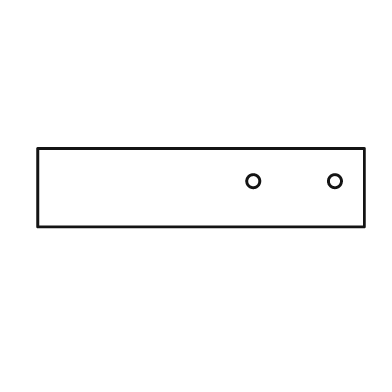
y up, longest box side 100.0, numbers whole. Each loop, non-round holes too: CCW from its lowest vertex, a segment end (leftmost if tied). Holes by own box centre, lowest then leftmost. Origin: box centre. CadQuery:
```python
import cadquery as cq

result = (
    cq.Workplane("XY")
    .moveTo(-50.0, -12.0)
    .lineTo(50.0, -12.0)
    .lineTo(50.0, 12.0)
    .lineTo(-50.0, 12.0)
    .close()
    .moveTo(16.0, 2.0)
    .circle(2.0)
    .moveTo(41.0, 2.0)
    .circle(2.0)
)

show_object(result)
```